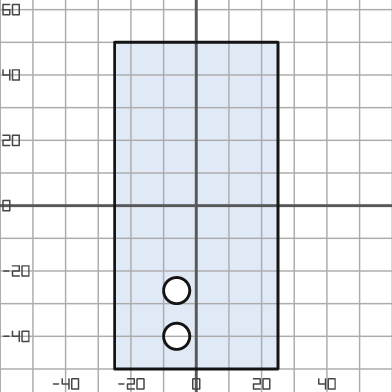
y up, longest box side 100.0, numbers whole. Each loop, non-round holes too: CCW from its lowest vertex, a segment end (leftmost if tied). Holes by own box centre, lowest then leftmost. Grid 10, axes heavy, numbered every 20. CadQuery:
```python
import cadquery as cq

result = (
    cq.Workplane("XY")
    .moveTo(-25.0, -50.0)
    .lineTo(25.0, -50.0)
    .lineTo(25.0, 50.0)
    .lineTo(-25.0, 50.0)
    .close()
    .moveTo(-6.0, -40.0)
    .circle(4.0)
    .moveTo(-6.0, -26.0)
    .circle(4.0)
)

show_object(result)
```